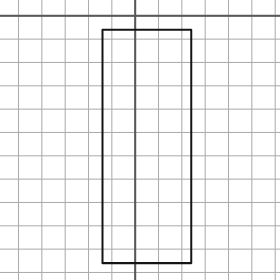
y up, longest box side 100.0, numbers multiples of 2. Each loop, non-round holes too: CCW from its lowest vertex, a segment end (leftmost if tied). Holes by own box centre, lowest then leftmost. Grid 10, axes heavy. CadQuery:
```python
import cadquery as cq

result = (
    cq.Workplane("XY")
    .moveTo(-14.0, -106.0)
    .lineTo(24.0, -106.0)
    .lineTo(24.0, -6.0)
    .lineTo(-14.0, -6.0)
    .close()
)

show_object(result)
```